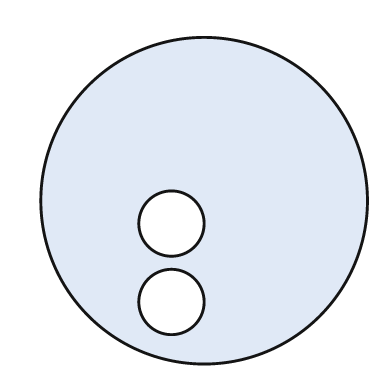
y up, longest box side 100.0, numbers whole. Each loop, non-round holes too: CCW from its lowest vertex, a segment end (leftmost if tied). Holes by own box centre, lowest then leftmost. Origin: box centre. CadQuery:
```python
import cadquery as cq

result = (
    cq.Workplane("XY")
    .moveTo(0.0, 0.0)
    .circle(50.0)
    .moveTo(-10.0, -31.0)
    .circle(10.0)
    .moveTo(-10.0, -7.0)
    .circle(10.0)
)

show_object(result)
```